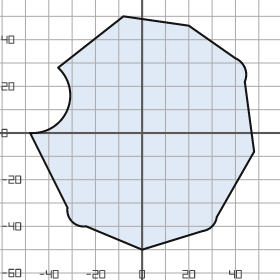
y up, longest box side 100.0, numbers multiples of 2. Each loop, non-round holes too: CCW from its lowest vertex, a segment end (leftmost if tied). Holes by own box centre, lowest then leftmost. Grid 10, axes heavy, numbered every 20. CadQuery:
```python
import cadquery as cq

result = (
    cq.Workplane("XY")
    .moveTo(0.0, -50.0)
    .lineTo(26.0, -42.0)
    .threePointArc((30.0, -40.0), (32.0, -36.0))
    .lineTo(48.0, -8.0)
    .lineTo(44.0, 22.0)
    .threePointArc((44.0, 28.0), (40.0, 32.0))
    .lineTo(20.0, 46.0)
    .lineTo(-8.0, 50.0)
    .lineTo(-36.0, 28.0)
    .threePointArc((-32.0, 10.0), (-48.0, 0.0))
    .lineTo(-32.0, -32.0)
    .threePointArc((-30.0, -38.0), (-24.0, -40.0))
    .close()
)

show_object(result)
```